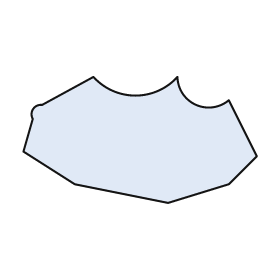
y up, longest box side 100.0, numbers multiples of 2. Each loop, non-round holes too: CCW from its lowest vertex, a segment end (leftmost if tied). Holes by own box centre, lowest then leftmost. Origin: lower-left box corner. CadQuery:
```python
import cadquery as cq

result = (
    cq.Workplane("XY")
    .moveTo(62.0, 0.0)
    .lineTo(88.0, 8.0)
    .lineTo(100.0, 20.0)
    .lineTo(88.0, 44.0)
    .threePointArc((74.0, 42.0), (66.0, 54.0))
    .threePointArc((48.0, 46.0), (30.0, 54.0))
    .lineTo(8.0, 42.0)
    .threePointArc((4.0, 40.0), (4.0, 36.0))
    .lineTo(0.0, 22.0)
    .lineTo(22.0, 8.0)
    .close()
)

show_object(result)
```